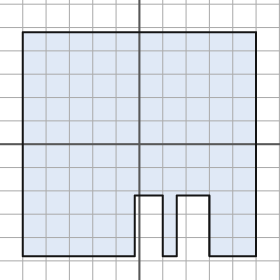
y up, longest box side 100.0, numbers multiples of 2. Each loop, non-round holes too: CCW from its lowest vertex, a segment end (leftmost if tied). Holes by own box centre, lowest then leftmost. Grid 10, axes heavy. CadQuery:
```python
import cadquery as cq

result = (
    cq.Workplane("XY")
    .moveTo(-50.0, -48.0)
    .lineTo(-2.0, -48.0)
    .lineTo(-2.0, -22.0)
    .lineTo(10.0, -22.0)
    .lineTo(10.0, -48.0)
    .lineTo(16.0, -48.0)
    .lineTo(16.0, -22.0)
    .lineTo(30.0, -22.0)
    .lineTo(30.0, -48.0)
    .lineTo(50.0, -48.0)
    .lineTo(50.0, 48.0)
    .lineTo(-50.0, 48.0)
    .close()
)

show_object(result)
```